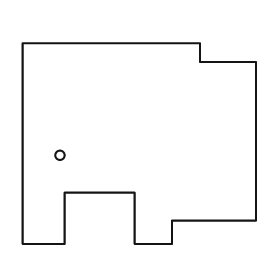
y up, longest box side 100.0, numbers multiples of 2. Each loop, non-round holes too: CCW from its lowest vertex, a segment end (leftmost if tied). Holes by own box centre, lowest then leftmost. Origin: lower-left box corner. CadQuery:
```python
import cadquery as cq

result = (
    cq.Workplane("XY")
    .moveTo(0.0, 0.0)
    .lineTo(18.0, 0.0)
    .lineTo(18.0, 22.0)
    .lineTo(48.0, 22.0)
    .lineTo(48.0, 0.0)
    .lineTo(64.0, 0.0)
    .lineTo(64.0, 10.0)
    .lineTo(100.0, 10.0)
    .lineTo(100.0, 78.0)
    .lineTo(76.0, 78.0)
    .lineTo(76.0, 86.0)
    .lineTo(0.0, 86.0)
    .close()
    .moveTo(16.0, 38.0)
    .circle(2.0)
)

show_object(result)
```